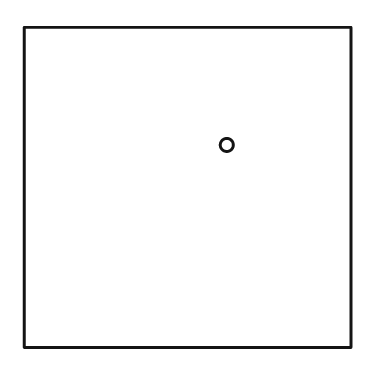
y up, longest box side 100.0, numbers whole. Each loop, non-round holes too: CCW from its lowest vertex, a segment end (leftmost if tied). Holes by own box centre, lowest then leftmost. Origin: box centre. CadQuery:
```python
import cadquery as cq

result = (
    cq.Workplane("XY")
    .moveTo(-50.0, -49.0)
    .lineTo(50.0, -49.0)
    .lineTo(50.0, 49.0)
    .lineTo(-50.0, 49.0)
    .close()
    .moveTo(12.0, 13.0)
    .circle(2.0)
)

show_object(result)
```